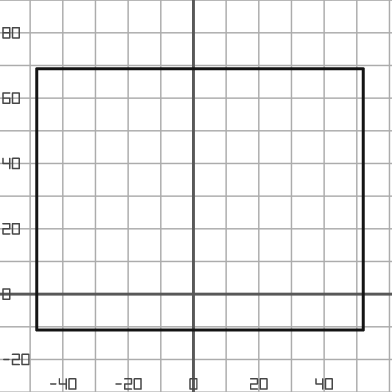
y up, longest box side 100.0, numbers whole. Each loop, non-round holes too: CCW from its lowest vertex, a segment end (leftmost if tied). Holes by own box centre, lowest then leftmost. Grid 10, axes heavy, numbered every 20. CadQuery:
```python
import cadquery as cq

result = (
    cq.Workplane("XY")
    .moveTo(-48.0, -11.0)
    .lineTo(52.0, -11.0)
    .lineTo(52.0, 69.0)
    .lineTo(-48.0, 69.0)
    .close()
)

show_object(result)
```